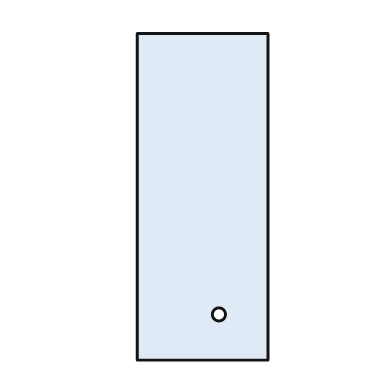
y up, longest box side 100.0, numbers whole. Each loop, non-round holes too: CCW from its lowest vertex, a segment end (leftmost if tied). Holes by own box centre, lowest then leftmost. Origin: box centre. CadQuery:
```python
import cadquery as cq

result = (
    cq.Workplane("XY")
    .moveTo(-20.0, -50.0)
    .lineTo(20.0, -50.0)
    .lineTo(20.0, 50.0)
    .lineTo(-20.0, 50.0)
    .close()
    .moveTo(5.0, -36.0)
    .circle(2.0)
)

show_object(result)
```